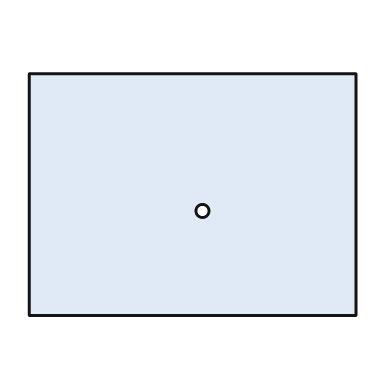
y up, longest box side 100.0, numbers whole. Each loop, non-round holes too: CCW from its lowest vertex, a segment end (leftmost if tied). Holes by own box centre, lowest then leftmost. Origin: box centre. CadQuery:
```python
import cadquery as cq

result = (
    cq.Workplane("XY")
    .moveTo(-50.0, -37.0)
    .lineTo(50.0, -37.0)
    .lineTo(50.0, 37.0)
    .lineTo(-50.0, 37.0)
    .close()
    .moveTo(3.0, -5.0)
    .circle(2.0)
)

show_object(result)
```